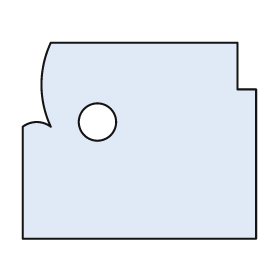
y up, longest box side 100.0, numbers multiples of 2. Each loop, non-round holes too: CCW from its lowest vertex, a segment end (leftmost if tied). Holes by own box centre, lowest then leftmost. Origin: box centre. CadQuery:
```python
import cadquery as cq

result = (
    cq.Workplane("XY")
    .moveTo(-50.0, -42.0)
    .lineTo(50.0, -42.0)
    .lineTo(50.0, 22.0)
    .lineTo(42.0, 22.0)
    .lineTo(42.0, 42.0)
    .lineTo(-38.0, 42.0)
    .threePointArc((-42.0, 24.0), (-38.0, 6.0))
    .threePointArc((-44.0, 8.0), (-50.0, 6.0))
    .close()
    .moveTo(-18.0, 8.0)
    .circle(8.0)
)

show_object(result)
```